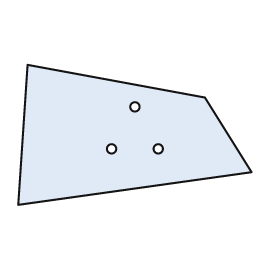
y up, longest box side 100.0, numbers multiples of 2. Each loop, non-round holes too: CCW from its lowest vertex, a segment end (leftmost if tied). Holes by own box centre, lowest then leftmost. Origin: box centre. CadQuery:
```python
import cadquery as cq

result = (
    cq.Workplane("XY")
    .moveTo(-50.0, -30.0)
    .lineTo(50.0, -16.0)
    .lineTo(30.0, 16.0)
    .lineTo(-46.0, 30.0)
    .close()
    .moveTo(-10.0, -6.0)
    .circle(2.0)
    .moveTo(10.0, -6.0)
    .circle(2.0)
    .moveTo(0.0, 12.0)
    .circle(2.0)
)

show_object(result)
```